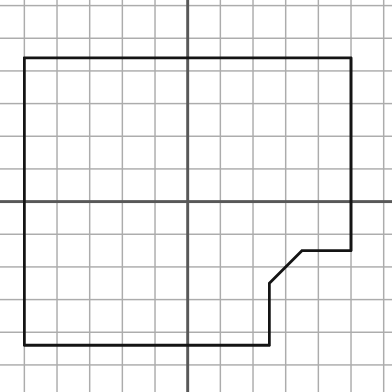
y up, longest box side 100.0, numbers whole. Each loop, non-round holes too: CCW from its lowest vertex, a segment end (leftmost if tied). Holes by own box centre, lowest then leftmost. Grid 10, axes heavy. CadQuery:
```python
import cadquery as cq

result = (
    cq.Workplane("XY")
    .moveTo(-50.0, -44.0)
    .lineTo(25.0, -44.0)
    .lineTo(25.0, -25.0)
    .lineTo(35.0, -15.0)
    .lineTo(50.0, -15.0)
    .lineTo(50.0, 44.0)
    .lineTo(-50.0, 44.0)
    .close()
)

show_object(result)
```